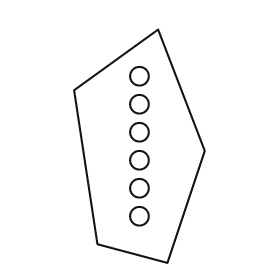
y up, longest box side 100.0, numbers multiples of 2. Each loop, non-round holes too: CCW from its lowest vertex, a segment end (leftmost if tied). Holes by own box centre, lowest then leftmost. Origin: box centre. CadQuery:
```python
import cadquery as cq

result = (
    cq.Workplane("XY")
    .moveTo(12.0, -50.0)
    .lineTo(28.0, -2.0)
    .lineTo(8.0, 50.0)
    .lineTo(-28.0, 24.0)
    .lineTo(-18.0, -42.0)
    .close()
    .moveTo(0.0, -30.0)
    .circle(4.0)
    .moveTo(0.0, -18.0)
    .circle(4.0)
    .moveTo(0.0, -6.0)
    .circle(4.0)
    .moveTo(0.0, 6.0)
    .circle(4.0)
    .moveTo(0.0, 18.0)
    .circle(4.0)
    .moveTo(0.0, 30.0)
    .circle(4.0)
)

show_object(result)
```